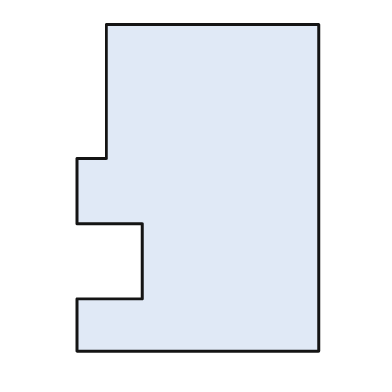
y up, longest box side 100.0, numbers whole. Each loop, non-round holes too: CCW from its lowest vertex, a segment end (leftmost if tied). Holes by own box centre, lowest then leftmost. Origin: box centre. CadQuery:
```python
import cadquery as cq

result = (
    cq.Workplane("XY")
    .moveTo(-37.0, -50.0)
    .lineTo(37.0, -50.0)
    .lineTo(37.0, 50.0)
    .lineTo(-28.0, 50.0)
    .lineTo(-28.0, 9.0)
    .lineTo(-37.0, 9.0)
    .lineTo(-37.0, -11.0)
    .lineTo(-17.0, -11.0)
    .lineTo(-17.0, -34.0)
    .lineTo(-37.0, -34.0)
    .close()
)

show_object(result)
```